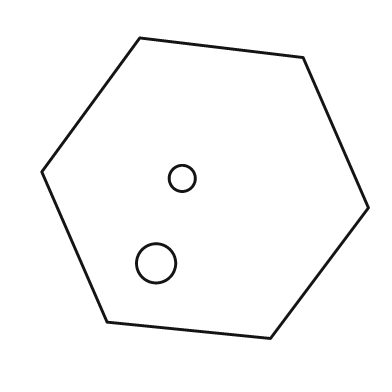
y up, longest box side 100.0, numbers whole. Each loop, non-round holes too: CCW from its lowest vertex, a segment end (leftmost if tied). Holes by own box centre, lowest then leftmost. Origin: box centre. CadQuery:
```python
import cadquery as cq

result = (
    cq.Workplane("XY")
    .moveTo(20.0, -46.0)
    .lineTo(50.0, -6.0)
    .lineTo(30.0, 40.0)
    .lineTo(-20.0, 46.0)
    .lineTo(-50.0, 5.0)
    .lineTo(-30.0, -41.0)
    .close()
    .moveTo(-15.0, -23.0)
    .circle(6.0)
    .moveTo(-7.0, 3.0)
    .circle(4.0)
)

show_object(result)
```